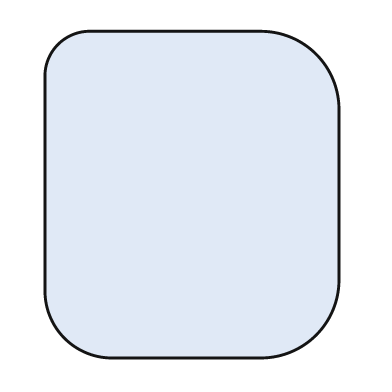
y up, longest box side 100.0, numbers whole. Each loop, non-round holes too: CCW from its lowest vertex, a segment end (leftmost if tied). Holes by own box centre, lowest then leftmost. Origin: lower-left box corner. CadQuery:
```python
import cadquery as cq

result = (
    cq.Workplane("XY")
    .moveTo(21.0, 0.0)
    .lineTo(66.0, 0.0)
    .threePointArc((83.0, 7.0), (90.0, 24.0))
    .lineTo(90.0, 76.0)
    .threePointArc((83.0, 93.0), (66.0, 100.0))
    .lineTo(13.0, 100.0)
    .threePointArc((4.0, 96.0), (0.0, 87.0))
    .lineTo(0.0, 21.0)
    .threePointArc((6.0, 6.0), (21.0, 0.0))
    .close()
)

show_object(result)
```